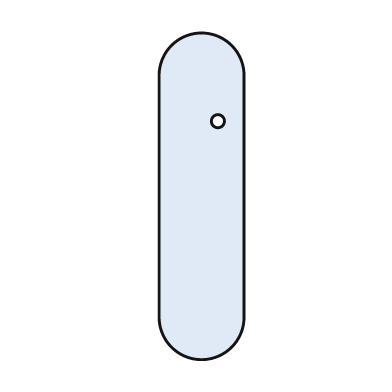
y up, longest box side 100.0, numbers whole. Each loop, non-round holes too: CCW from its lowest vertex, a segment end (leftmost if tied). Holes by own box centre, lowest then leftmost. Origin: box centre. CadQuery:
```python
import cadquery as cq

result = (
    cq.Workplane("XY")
    .moveTo(-13.0, -37.0)
    .threePointArc((0.0, -50.0), (13.0, -37.0))
    .lineTo(13.0, 37.0)
    .threePointArc((0.0, 50.0), (-13.0, 37.0))
    .close()
    .moveTo(5.0, 23.0)
    .circle(2.0)
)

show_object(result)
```